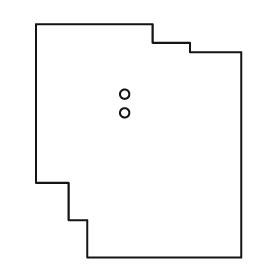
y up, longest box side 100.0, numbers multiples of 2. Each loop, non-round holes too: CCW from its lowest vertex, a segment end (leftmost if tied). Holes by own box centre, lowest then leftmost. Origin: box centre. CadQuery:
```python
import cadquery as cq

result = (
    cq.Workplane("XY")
    .moveTo(-22.0, -50.0)
    .lineTo(44.0, -50.0)
    .lineTo(44.0, 38.0)
    .lineTo(22.0, 38.0)
    .lineTo(22.0, 42.0)
    .lineTo(6.0, 42.0)
    .lineTo(6.0, 50.0)
    .lineTo(-44.0, 50.0)
    .lineTo(-44.0, -18.0)
    .lineTo(-30.0, -18.0)
    .lineTo(-30.0, -34.0)
    .lineTo(-22.0, -34.0)
    .close()
    .moveTo(-6.0, 12.0)
    .circle(2.0)
    .moveTo(-6.0, 20.0)
    .circle(2.0)
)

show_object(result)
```